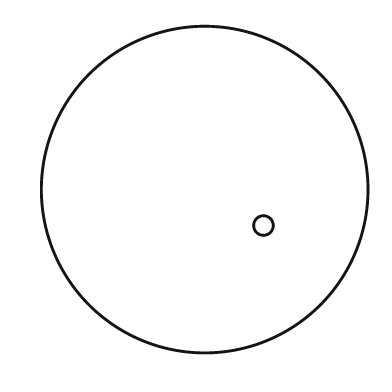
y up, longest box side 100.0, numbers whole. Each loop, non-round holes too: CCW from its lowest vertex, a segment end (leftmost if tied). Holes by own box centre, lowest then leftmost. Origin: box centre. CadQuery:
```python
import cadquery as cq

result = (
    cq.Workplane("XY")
    .moveTo(0.0, 0.0)
    .circle(50.0)
    .moveTo(18.0, -11.0)
    .circle(3.0)
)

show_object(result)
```